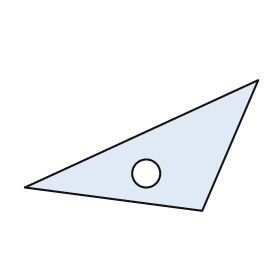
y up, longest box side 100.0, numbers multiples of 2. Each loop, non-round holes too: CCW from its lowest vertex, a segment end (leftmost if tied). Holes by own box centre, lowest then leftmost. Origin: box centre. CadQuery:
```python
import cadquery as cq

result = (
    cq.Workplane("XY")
    .moveTo(26.0, -28.0)
    .lineTo(50.0, 28.0)
    .lineTo(-50.0, -18.0)
    .close()
    .moveTo(2.0, -12.0)
    .circle(6.0)
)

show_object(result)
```